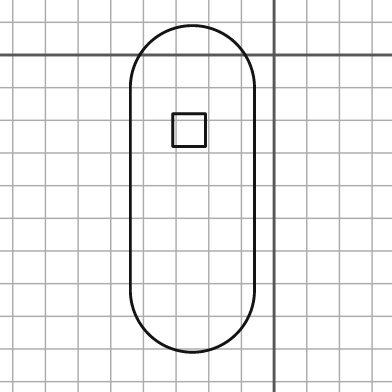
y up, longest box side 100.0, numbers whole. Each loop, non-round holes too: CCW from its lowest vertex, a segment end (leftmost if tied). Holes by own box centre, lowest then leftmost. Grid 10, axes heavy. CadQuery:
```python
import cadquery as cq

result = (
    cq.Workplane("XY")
    .moveTo(-44.0, -72.0)
    .threePointArc((-25.0, -91.0), (-6.0, -72.0))
    .lineTo(-6.0, -10.0)
    .threePointArc((-25.0, 9.0), (-44.0, -10.0))
    .close()
    .moveTo(-31.0, -28.0)
    .lineTo(-21.0, -28.0)
    .lineTo(-21.0, -18.0)
    .lineTo(-31.0, -18.0)
    .close()
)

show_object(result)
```